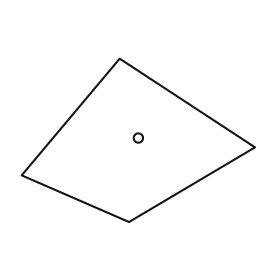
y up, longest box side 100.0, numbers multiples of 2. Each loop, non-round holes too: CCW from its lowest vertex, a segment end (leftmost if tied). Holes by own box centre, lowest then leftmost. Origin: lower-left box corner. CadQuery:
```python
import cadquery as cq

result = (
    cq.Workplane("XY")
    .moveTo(46.0, 0.0)
    .lineTo(100.0, 32.0)
    .lineTo(42.0, 70.0)
    .lineTo(0.0, 20.0)
    .close()
    .moveTo(50.0, 36.0)
    .circle(2.0)
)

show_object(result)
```